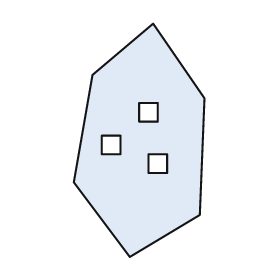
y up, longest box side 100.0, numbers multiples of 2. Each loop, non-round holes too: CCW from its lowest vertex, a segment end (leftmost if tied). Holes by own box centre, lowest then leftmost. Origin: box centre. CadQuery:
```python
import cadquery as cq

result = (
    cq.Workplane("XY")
    .moveTo(-4.0, -50.0)
    .lineTo(26.0, -32.0)
    .lineTo(28.0, 18.0)
    .lineTo(6.0, 50.0)
    .lineTo(-20.0, 28.0)
    .lineTo(-28.0, -18.0)
    .close()
    .moveTo(4.0, -14.0)
    .lineTo(12.0, -14.0)
    .lineTo(12.0, -6.0)
    .lineTo(4.0, -6.0)
    .close()
    .moveTo(-16.0, -6.0)
    .lineTo(-8.0, -6.0)
    .lineTo(-8.0, 2.0)
    .lineTo(-16.0, 2.0)
    .close()
    .moveTo(0.0, 8.0)
    .lineTo(8.0, 8.0)
    .lineTo(8.0, 16.0)
    .lineTo(0.0, 16.0)
    .close()
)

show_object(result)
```